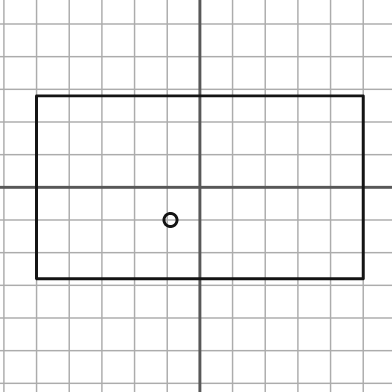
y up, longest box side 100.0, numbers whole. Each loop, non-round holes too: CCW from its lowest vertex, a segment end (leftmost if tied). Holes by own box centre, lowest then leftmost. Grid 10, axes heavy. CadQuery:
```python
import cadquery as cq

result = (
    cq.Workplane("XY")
    .moveTo(-50.0, -28.0)
    .lineTo(50.0, -28.0)
    .lineTo(50.0, 28.0)
    .lineTo(-50.0, 28.0)
    .close()
    .moveTo(-9.0, -10.0)
    .circle(2.0)
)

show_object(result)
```